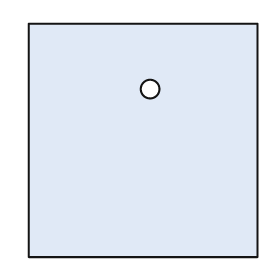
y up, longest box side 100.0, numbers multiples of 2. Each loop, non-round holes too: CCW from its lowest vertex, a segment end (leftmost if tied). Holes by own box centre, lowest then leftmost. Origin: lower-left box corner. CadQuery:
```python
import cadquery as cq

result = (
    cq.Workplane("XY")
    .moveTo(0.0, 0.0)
    .lineTo(98.0, 0.0)
    .lineTo(98.0, 100.0)
    .lineTo(0.0, 100.0)
    .close()
    .moveTo(52.0, 72.0)
    .circle(4.0)
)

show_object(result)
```